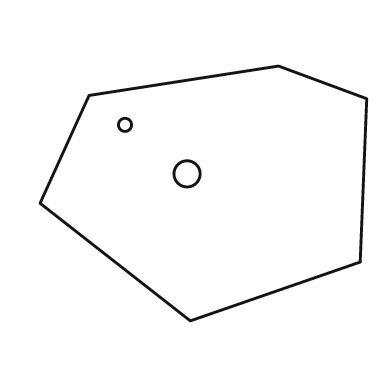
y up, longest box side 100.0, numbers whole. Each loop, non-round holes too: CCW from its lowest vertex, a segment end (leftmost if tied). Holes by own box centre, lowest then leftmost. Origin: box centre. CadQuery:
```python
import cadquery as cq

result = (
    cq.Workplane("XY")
    .moveTo(-4.0, -39.0)
    .lineTo(48.0, -21.0)
    .lineTo(50.0, 29.0)
    .lineTo(23.0, 39.0)
    .lineTo(-35.0, 30.0)
    .lineTo(-50.0, -3.0)
    .close()
    .moveTo(-5.0, 6.0)
    .circle(4.0)
    .moveTo(-24.0, 21.0)
    .circle(2.0)
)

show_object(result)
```